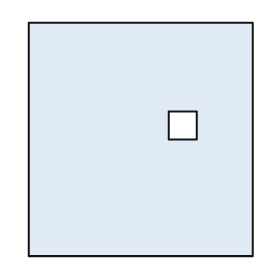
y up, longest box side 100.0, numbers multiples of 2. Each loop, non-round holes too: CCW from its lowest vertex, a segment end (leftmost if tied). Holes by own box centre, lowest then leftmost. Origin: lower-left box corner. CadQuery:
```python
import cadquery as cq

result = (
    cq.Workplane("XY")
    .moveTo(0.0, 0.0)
    .lineTo(96.0, 0.0)
    .lineTo(96.0, 100.0)
    .lineTo(0.0, 100.0)
    .close()
    .moveTo(60.0, 50.0)
    .lineTo(72.0, 50.0)
    .lineTo(72.0, 62.0)
    .lineTo(60.0, 62.0)
    .close()
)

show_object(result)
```